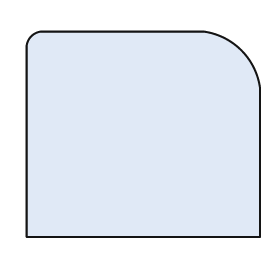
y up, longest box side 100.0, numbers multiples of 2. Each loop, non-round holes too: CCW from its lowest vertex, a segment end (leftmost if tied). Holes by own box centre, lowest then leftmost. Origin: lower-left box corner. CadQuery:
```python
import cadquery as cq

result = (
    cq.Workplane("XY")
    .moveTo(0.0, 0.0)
    .lineTo(100.0, 0.0)
    .lineTo(100.0, 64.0)
    .threePointArc((92.0, 80.0), (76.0, 88.0))
    .lineTo(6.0, 88.0)
    .threePointArc((2.0, 86.0), (0.0, 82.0))
    .close()
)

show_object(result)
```